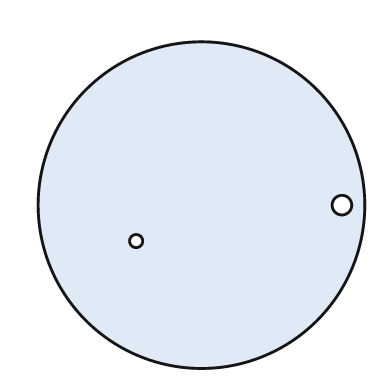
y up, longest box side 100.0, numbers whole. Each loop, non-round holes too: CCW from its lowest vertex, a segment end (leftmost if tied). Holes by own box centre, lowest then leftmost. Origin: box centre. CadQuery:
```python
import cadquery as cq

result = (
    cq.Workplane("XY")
    .moveTo(0.0, 0.0)
    .circle(50.0)
    .moveTo(-20.0, -11.0)
    .circle(2.0)
    .moveTo(43.0, 0.0)
    .circle(3.0)
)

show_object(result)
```